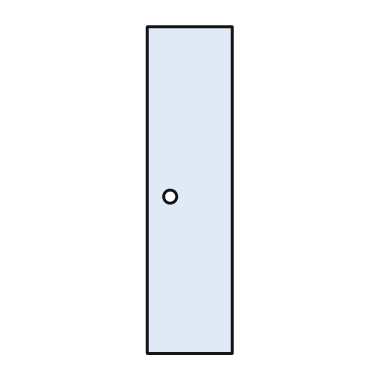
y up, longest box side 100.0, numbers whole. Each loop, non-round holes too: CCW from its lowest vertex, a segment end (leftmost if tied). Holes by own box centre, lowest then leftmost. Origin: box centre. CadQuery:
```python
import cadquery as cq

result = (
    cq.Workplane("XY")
    .moveTo(-13.0, -50.0)
    .lineTo(13.0, -50.0)
    .lineTo(13.0, 50.0)
    .lineTo(-13.0, 50.0)
    .close()
    .moveTo(-6.0, -2.0)
    .circle(2.0)
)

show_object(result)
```